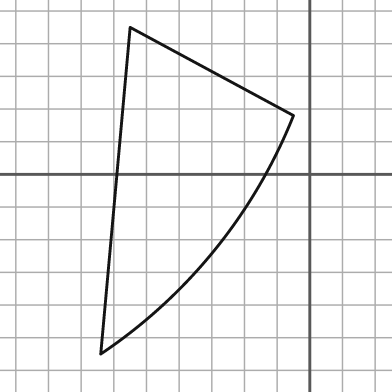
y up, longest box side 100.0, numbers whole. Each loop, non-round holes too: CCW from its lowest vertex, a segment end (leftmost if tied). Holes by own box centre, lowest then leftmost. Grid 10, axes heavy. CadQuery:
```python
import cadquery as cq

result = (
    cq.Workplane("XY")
    .moveTo(-64.0, -55.0)
    .threePointArc((-29.0, -23.0), (-5.0, 18.0))
    .lineTo(-55.0, 45.0)
    .close()
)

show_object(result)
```